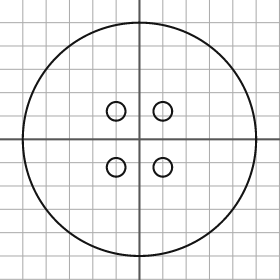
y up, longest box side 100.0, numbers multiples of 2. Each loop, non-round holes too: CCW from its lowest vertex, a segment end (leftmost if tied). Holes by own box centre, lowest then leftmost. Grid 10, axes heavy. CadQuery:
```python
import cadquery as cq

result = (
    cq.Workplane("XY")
    .moveTo(0.0, 0.0)
    .circle(50.0)
    .moveTo(-10.0, -12.0)
    .circle(4.0)
    .moveTo(10.0, -12.0)
    .circle(4.0)
    .moveTo(-10.0, 12.0)
    .circle(4.0)
    .moveTo(10.0, 12.0)
    .circle(4.0)
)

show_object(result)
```